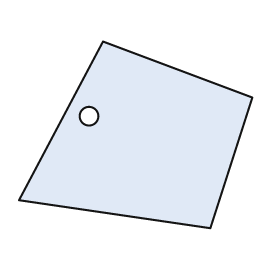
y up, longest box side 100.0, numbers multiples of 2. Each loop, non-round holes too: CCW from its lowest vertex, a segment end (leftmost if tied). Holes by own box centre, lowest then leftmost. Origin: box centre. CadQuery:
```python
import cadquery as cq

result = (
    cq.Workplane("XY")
    .moveTo(32.0, -40.0)
    .lineTo(50.0, 16.0)
    .lineTo(-14.0, 40.0)
    .lineTo(-50.0, -28.0)
    .close()
    .moveTo(-20.0, 8.0)
    .circle(4.0)
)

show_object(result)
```